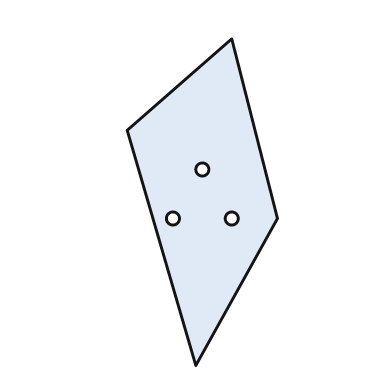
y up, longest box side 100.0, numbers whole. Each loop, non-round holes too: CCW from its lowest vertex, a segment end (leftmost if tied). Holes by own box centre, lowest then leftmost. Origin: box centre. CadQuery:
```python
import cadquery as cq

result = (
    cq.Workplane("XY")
    .moveTo(-2.0, -50.0)
    .lineTo(23.0, -5.0)
    .lineTo(9.0, 50.0)
    .lineTo(-23.0, 22.0)
    .close()
    .moveTo(-9.0, -5.0)
    .circle(2.0)
    .moveTo(9.0, -5.0)
    .circle(2.0)
    .moveTo(0.0, 10.0)
    .circle(2.0)
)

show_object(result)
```